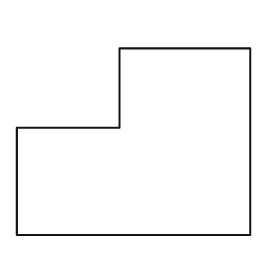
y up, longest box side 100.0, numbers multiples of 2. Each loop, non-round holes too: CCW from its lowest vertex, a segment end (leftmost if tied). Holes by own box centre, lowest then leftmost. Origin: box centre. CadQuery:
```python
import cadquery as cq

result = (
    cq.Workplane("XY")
    .moveTo(-50.0, -40.0)
    .lineTo(50.0, -40.0)
    .lineTo(50.0, 40.0)
    .lineTo(-6.0, 40.0)
    .lineTo(-6.0, 6.0)
    .lineTo(-50.0, 6.0)
    .close()
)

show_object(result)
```